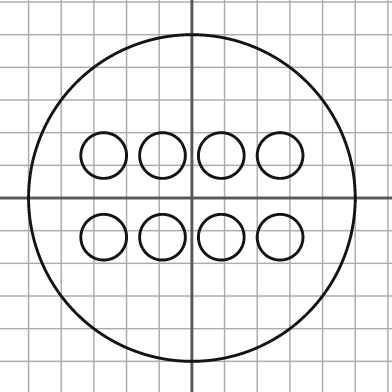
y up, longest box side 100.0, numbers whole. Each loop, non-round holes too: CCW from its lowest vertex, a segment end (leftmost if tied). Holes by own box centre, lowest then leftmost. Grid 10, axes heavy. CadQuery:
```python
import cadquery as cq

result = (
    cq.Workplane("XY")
    .moveTo(0.0, 0.0)
    .circle(50.0)
    .moveTo(-27.0, -12.0)
    .circle(7.0)
    .moveTo(-9.0, -12.0)
    .circle(7.0)
    .moveTo(9.0, -12.0)
    .circle(7.0)
    .moveTo(27.0, -12.0)
    .circle(7.0)
    .moveTo(-27.0, 13.0)
    .circle(7.0)
    .moveTo(-9.0, 13.0)
    .circle(7.0)
    .moveTo(9.0, 13.0)
    .circle(7.0)
    .moveTo(27.0, 13.0)
    .circle(7.0)
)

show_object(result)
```